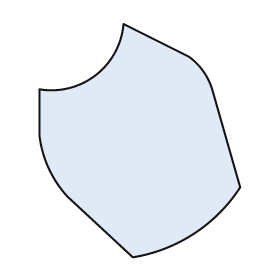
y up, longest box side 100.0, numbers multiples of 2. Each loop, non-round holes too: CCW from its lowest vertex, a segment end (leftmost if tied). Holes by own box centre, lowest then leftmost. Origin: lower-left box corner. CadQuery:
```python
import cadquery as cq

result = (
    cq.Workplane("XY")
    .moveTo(40.0, 0.0)
    .threePointArc((66.0, 10.0), (86.0, 30.0))
    .lineTo(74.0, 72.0)
    .threePointArc((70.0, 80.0), (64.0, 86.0))
    .lineTo(36.0, 100.0)
    .threePointArc((24.0, 78.0), (0.0, 72.0))
    .lineTo(0.0, 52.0)
    .threePointArc((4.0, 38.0), (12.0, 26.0))
    .close()
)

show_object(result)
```